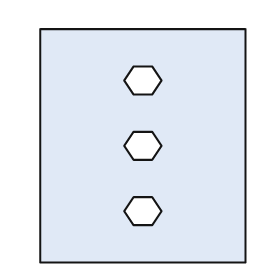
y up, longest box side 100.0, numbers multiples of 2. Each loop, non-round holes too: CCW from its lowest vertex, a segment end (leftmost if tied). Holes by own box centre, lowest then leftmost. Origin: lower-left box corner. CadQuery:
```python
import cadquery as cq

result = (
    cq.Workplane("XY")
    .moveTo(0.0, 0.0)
    .lineTo(88.0, 0.0)
    .lineTo(88.0, 100.0)
    .lineTo(0.0, 100.0)
    .close()
    .moveTo(40.0, 16.0)
    .lineTo(48.0, 16.0)
    .lineTo(52.0, 22.0)
    .lineTo(48.0, 28.0)
    .lineTo(40.0, 28.0)
    .lineTo(36.0, 22.0)
    .close()
    .moveTo(40.0, 44.0)
    .lineTo(48.0, 44.0)
    .lineTo(52.0, 50.0)
    .lineTo(48.0, 56.0)
    .lineTo(40.0, 56.0)
    .lineTo(36.0, 50.0)
    .close()
    .moveTo(40.0, 72.0)
    .lineTo(48.0, 72.0)
    .lineTo(52.0, 78.0)
    .lineTo(48.0, 84.0)
    .lineTo(40.0, 84.0)
    .lineTo(36.0, 78.0)
    .close()
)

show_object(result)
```